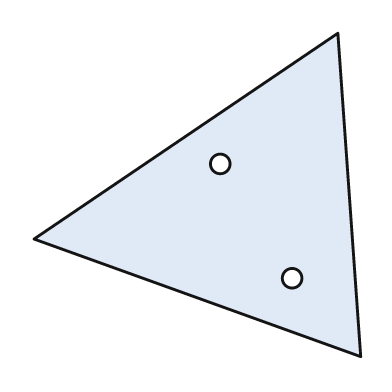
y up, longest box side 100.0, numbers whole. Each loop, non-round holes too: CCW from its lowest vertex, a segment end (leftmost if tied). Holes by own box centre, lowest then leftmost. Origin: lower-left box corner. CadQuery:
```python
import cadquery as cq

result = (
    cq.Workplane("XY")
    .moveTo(100.0, 0.0)
    .lineTo(93.0, 99.0)
    .lineTo(0.0, 36.0)
    .close()
    .moveTo(79.0, 24.0)
    .circle(3.0)
    .moveTo(57.0, 59.0)
    .circle(3.0)
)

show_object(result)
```